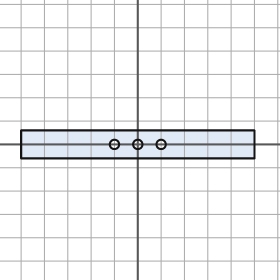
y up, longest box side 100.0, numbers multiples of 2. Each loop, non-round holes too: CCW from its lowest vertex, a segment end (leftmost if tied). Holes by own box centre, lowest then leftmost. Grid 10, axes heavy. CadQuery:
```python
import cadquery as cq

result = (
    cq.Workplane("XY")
    .moveTo(-50.0, -6.0)
    .lineTo(50.0, -6.0)
    .lineTo(50.0, 6.0)
    .lineTo(-50.0, 6.0)
    .close()
    .moveTo(-10.0, 0.0)
    .circle(2.0)
    .moveTo(0.0, 0.0)
    .circle(2.0)
    .moveTo(10.0, 0.0)
    .circle(2.0)
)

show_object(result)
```